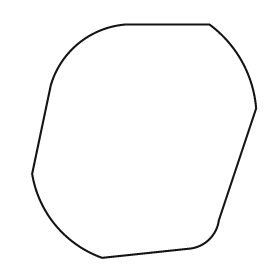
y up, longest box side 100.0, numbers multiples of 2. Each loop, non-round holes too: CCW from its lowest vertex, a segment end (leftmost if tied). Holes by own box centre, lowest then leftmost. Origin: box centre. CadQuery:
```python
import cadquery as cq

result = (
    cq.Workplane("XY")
    .moveTo(-18.0, -50.0)
    .lineTo(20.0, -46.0)
    .threePointArc((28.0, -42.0), (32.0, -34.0))
    .lineTo(48.0, 14.0)
    .threePointArc((42.0, 34.0), (28.0, 50.0))
    .lineTo(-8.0, 50.0)
    .threePointArc((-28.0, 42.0), (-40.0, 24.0))
    .lineTo(-48.0, -14.0)
    .threePointArc((-38.0, -36.0), (-18.0, -50.0))
    .close()
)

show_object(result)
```